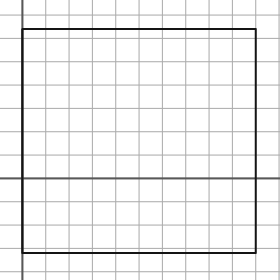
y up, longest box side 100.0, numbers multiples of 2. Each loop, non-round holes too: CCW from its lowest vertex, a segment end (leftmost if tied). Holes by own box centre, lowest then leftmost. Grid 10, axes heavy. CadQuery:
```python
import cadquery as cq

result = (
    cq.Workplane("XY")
    .moveTo(0.0, -32.0)
    .lineTo(100.0, -32.0)
    .lineTo(100.0, 64.0)
    .lineTo(0.0, 64.0)
    .close()
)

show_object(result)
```